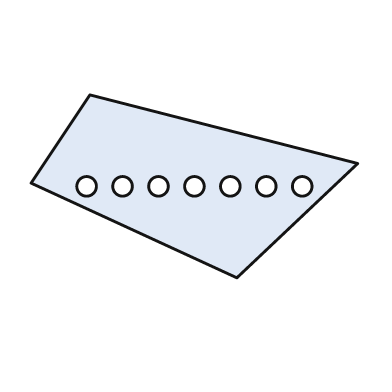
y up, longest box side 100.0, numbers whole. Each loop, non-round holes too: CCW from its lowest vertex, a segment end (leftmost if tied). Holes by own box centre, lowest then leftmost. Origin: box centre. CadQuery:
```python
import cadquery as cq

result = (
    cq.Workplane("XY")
    .moveTo(13.0, -28.0)
    .lineTo(50.0, 7.0)
    .lineTo(-32.0, 28.0)
    .lineTo(-50.0, 1.0)
    .close()
    .moveTo(-33.0, 0.0)
    .circle(3.0)
    .moveTo(-22.0, 0.0)
    .circle(3.0)
    .moveTo(-11.0, 0.0)
    .circle(3.0)
    .moveTo(0.0, 0.0)
    .circle(3.0)
    .moveTo(11.0, 0.0)
    .circle(3.0)
    .moveTo(22.0, 0.0)
    .circle(3.0)
    .moveTo(33.0, 0.0)
    .circle(3.0)
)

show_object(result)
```